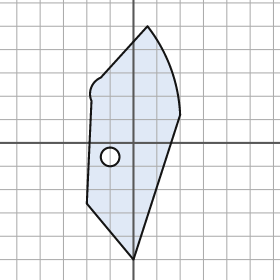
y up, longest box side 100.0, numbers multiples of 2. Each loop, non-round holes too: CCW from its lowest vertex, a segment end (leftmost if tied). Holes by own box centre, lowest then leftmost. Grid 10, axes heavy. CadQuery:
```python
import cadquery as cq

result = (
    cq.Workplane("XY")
    .moveTo(0.0, -50.0)
    .lineTo(20.0, 12.0)
    .threePointArc((16.0, 32.0), (6.0, 50.0))
    .lineTo(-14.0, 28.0)
    .threePointArc((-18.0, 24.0), (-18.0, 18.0))
    .lineTo(-20.0, -26.0)
    .close()
    .moveTo(-10.0, -6.0)
    .circle(4.0)
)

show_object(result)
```